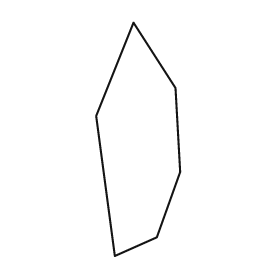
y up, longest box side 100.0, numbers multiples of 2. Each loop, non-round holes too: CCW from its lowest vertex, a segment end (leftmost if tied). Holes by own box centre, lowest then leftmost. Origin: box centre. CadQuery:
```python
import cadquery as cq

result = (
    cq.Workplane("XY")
    .moveTo(-10.0, -50.0)
    .lineTo(8.0, -42.0)
    .lineTo(18.0, -14.0)
    .lineTo(16.0, 22.0)
    .lineTo(-2.0, 50.0)
    .lineTo(-18.0, 10.0)
    .close()
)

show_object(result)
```